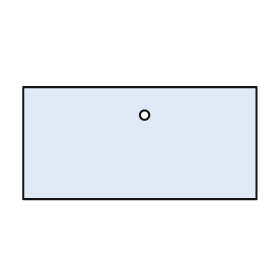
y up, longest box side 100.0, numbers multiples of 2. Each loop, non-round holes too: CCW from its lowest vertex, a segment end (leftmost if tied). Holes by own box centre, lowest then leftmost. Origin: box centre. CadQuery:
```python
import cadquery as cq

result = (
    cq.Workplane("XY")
    .moveTo(-50.0, -24.0)
    .lineTo(50.0, -24.0)
    .lineTo(50.0, 24.0)
    .lineTo(-50.0, 24.0)
    .close()
    .moveTo(2.0, 12.0)
    .circle(2.0)
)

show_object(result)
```